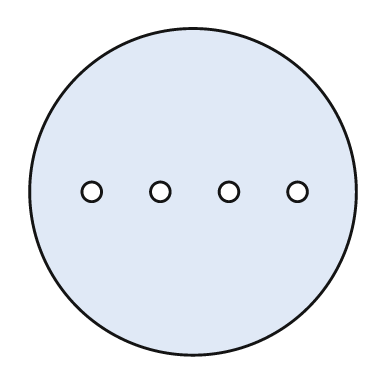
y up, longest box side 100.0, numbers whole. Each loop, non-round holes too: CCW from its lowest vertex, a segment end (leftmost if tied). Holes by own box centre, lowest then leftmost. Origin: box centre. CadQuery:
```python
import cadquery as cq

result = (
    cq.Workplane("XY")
    .moveTo(0.0, 0.0)
    .circle(50.0)
    .moveTo(-31.0, 0.0)
    .circle(3.0)
    .moveTo(-10.0, 0.0)
    .circle(3.0)
    .moveTo(11.0, 0.0)
    .circle(3.0)
    .moveTo(32.0, 0.0)
    .circle(3.0)
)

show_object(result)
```